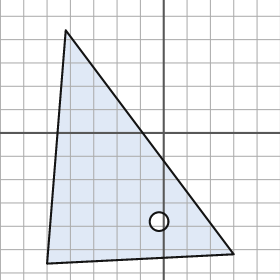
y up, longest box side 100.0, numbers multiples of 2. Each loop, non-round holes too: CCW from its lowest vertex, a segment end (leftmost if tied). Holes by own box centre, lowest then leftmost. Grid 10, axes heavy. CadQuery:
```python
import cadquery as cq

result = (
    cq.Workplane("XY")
    .moveTo(-50.0, -56.0)
    .lineTo(30.0, -52.0)
    .lineTo(-42.0, 44.0)
    .close()
    .moveTo(-2.0, -38.0)
    .circle(4.0)
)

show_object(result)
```